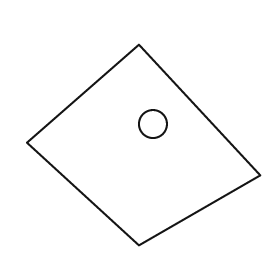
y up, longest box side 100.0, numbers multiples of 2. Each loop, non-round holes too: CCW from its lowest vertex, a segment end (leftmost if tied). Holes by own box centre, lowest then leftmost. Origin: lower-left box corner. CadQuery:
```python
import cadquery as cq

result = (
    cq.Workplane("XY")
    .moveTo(48.0, 0.0)
    .lineTo(100.0, 30.0)
    .lineTo(48.0, 86.0)
    .lineTo(0.0, 44.0)
    .close()
    .moveTo(54.0, 52.0)
    .circle(6.0)
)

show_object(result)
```